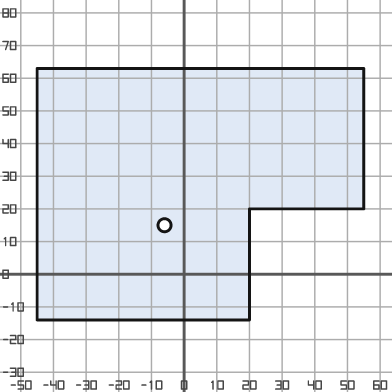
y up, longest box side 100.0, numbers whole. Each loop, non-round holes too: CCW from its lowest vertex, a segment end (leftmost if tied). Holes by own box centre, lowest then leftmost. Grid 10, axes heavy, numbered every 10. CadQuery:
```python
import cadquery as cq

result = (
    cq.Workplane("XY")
    .moveTo(-45.0, -14.0)
    .lineTo(20.0, -14.0)
    .lineTo(20.0, 20.0)
    .lineTo(55.0, 20.0)
    .lineTo(55.0, 63.0)
    .lineTo(-45.0, 63.0)
    .close()
    .moveTo(-6.0, 15.0)
    .circle(2.0)
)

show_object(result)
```